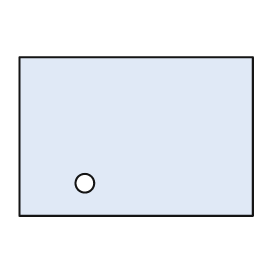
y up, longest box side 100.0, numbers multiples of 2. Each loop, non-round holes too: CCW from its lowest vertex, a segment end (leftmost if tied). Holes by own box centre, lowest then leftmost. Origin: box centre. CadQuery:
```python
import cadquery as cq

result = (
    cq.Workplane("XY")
    .moveTo(-50.0, -34.0)
    .lineTo(50.0, -34.0)
    .lineTo(50.0, 34.0)
    .lineTo(-50.0, 34.0)
    .close()
    .moveTo(-22.0, -20.0)
    .circle(4.0)
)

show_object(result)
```